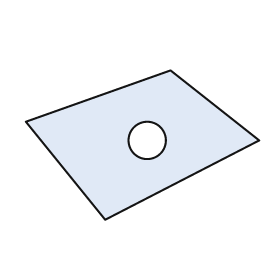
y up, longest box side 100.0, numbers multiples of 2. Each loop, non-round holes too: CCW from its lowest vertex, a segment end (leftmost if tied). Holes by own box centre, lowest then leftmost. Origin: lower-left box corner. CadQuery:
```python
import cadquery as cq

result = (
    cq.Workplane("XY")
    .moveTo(34.0, 0.0)
    .lineTo(100.0, 34.0)
    .lineTo(62.0, 64.0)
    .lineTo(0.0, 42.0)
    .close()
    .moveTo(52.0, 34.0)
    .circle(8.0)
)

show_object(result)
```